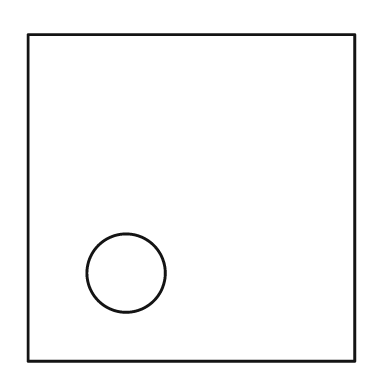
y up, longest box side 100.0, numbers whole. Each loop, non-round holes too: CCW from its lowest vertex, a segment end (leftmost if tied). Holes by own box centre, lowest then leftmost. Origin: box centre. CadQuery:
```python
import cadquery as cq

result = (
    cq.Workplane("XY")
    .moveTo(-50.0, -50.0)
    .lineTo(50.0, -50.0)
    .lineTo(50.0, 50.0)
    .lineTo(-50.0, 50.0)
    .close()
    .moveTo(-20.0, -23.0)
    .circle(12.0)
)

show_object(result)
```